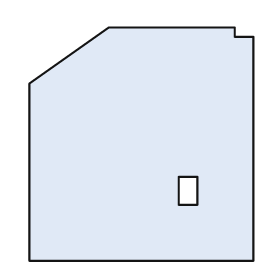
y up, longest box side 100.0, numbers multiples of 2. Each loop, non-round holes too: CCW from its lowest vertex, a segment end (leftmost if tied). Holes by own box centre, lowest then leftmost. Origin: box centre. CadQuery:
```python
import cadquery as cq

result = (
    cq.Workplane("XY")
    .moveTo(-48.0, -50.0)
    .lineTo(48.0, -50.0)
    .lineTo(48.0, 46.0)
    .lineTo(40.0, 46.0)
    .lineTo(40.0, 50.0)
    .lineTo(-14.0, 50.0)
    .lineTo(-48.0, 26.0)
    .close()
    .moveTo(16.0, -26.0)
    .lineTo(24.0, -26.0)
    .lineTo(24.0, -14.0)
    .lineTo(16.0, -14.0)
    .close()
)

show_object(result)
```